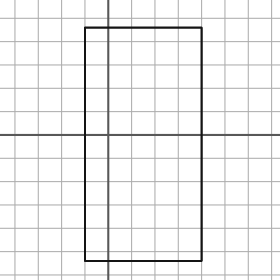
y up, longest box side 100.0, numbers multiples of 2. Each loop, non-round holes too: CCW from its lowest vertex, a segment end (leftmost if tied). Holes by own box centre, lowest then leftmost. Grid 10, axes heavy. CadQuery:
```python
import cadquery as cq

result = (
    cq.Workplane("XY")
    .moveTo(-10.0, -54.0)
    .lineTo(40.0, -54.0)
    .lineTo(40.0, 46.0)
    .lineTo(-10.0, 46.0)
    .close()
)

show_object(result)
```